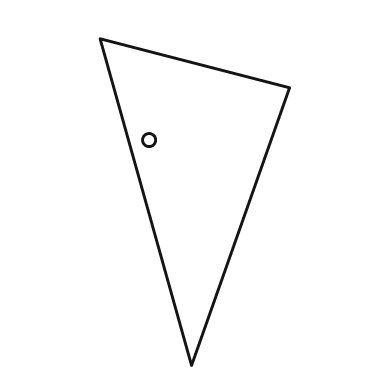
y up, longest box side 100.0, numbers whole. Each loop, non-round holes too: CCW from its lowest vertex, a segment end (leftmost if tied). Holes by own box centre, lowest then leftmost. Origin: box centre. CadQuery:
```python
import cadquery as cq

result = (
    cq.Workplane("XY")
    .moveTo(-1.0, -50.0)
    .lineTo(29.0, 35.0)
    .lineTo(-29.0, 50.0)
    .close()
    .moveTo(-14.0, 19.0)
    .circle(2.0)
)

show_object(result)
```